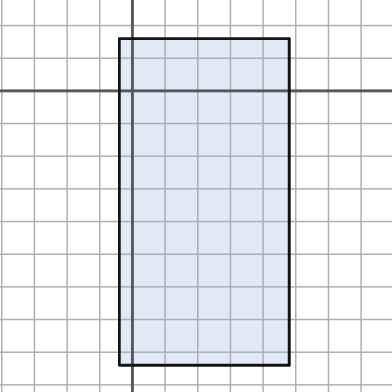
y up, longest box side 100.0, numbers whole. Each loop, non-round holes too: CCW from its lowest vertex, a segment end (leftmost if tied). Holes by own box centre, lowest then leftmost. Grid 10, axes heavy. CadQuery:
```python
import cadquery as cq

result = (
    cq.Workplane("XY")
    .moveTo(-4.0, -84.0)
    .lineTo(48.0, -84.0)
    .lineTo(48.0, 16.0)
    .lineTo(-4.0, 16.0)
    .close()
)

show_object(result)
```